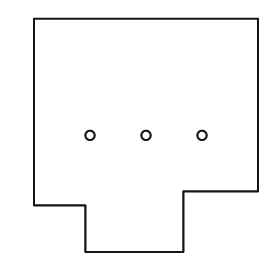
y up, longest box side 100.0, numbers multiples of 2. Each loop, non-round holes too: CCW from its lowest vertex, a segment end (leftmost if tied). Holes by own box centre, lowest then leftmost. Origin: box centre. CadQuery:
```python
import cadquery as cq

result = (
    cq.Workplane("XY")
    .moveTo(-26.0, -50.0)
    .lineTo(16.0, -50.0)
    .lineTo(16.0, -24.0)
    .lineTo(48.0, -24.0)
    .lineTo(48.0, 50.0)
    .lineTo(-48.0, 50.0)
    .lineTo(-48.0, -30.0)
    .lineTo(-26.0, -30.0)
    .close()
    .moveTo(-24.0, 0.0)
    .circle(2.0)
    .moveTo(0.0, 0.0)
    .circle(2.0)
    .moveTo(24.0, 0.0)
    .circle(2.0)
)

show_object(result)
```